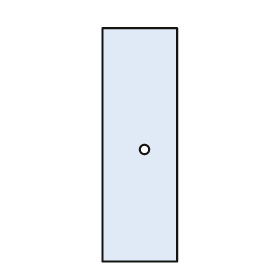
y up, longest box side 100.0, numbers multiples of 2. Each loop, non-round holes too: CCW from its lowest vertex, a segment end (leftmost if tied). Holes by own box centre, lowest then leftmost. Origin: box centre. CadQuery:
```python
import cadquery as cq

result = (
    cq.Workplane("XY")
    .moveTo(-16.0, -50.0)
    .lineTo(16.0, -50.0)
    .lineTo(16.0, 50.0)
    .lineTo(-16.0, 50.0)
    .close()
    .moveTo(2.0, -2.0)
    .circle(2.0)
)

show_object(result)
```